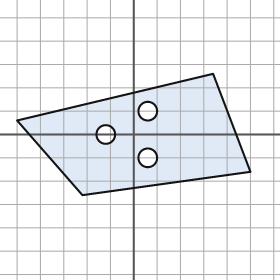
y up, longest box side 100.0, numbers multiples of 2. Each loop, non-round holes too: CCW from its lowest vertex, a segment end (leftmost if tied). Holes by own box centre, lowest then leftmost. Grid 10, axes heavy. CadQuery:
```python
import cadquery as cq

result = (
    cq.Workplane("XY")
    .moveTo(-22.0, -26.0)
    .lineTo(50.0, -16.0)
    .lineTo(34.0, 26.0)
    .lineTo(-50.0, 6.0)
    .close()
    .moveTo(6.0, -10.0)
    .circle(4.0)
    .moveTo(-12.0, 0.0)
    .circle(4.0)
    .moveTo(6.0, 10.0)
    .circle(4.0)
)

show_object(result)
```